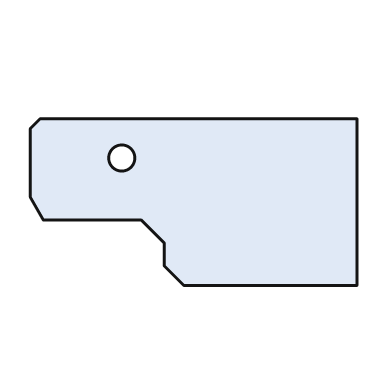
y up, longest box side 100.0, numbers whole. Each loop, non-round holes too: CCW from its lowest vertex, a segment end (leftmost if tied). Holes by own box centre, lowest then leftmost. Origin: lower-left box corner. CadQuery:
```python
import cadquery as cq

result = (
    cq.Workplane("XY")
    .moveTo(47.0, 0.0)
    .lineTo(100.0, 0.0)
    .lineTo(100.0, 51.0)
    .lineTo(3.0, 51.0)
    .lineTo(0.0, 48.0)
    .lineTo(0.0, 27.0)
    .lineTo(4.0, 20.0)
    .lineTo(34.0, 20.0)
    .lineTo(41.0, 13.0)
    .lineTo(41.0, 6.0)
    .close()
    .moveTo(28.0, 39.0)
    .circle(4.0)
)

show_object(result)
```